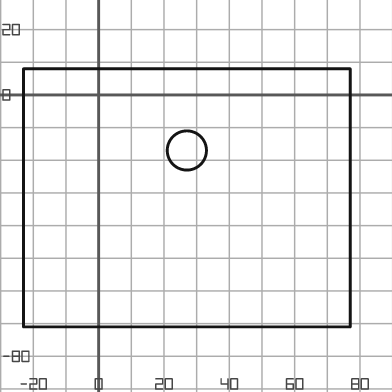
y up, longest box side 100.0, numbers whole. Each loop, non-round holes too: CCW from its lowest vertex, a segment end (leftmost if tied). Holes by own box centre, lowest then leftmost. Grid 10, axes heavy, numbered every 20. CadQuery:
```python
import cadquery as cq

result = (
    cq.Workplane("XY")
    .moveTo(-23.0, -71.0)
    .lineTo(77.0, -71.0)
    .lineTo(77.0, 8.0)
    .lineTo(-23.0, 8.0)
    .close()
    .moveTo(27.0, -17.0)
    .circle(6.0)
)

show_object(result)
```